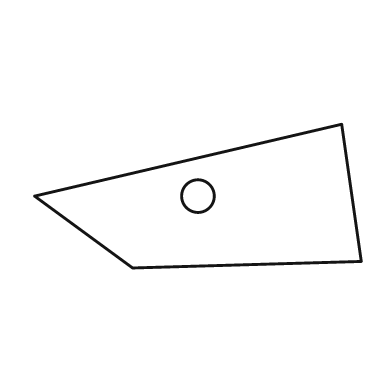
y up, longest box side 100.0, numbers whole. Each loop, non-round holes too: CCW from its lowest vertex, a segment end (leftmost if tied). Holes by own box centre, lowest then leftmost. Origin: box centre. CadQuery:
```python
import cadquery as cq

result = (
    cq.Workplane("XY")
    .moveTo(-20.0, -22.0)
    .lineTo(50.0, -20.0)
    .lineTo(44.0, 22.0)
    .lineTo(-50.0, 0.0)
    .close()
    .moveTo(0.0, 0.0)
    .circle(5.0)
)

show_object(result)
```